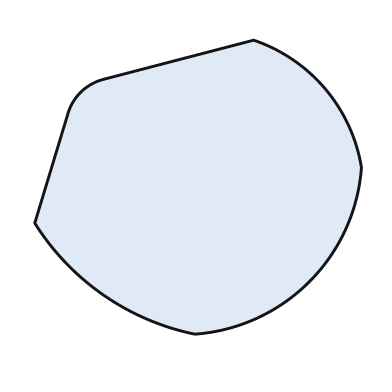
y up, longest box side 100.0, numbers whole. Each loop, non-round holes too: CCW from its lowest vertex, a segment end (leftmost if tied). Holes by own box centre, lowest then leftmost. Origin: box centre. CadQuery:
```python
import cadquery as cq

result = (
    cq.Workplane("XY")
    .moveTo(-1.0, -45.0)
    .threePointArc((34.0, -29.0), (50.0, 6.0))
    .threePointArc((39.0, 30.0), (17.0, 45.0))
    .lineTo(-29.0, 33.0)
    .threePointArc((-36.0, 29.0), (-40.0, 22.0))
    .lineTo(-50.0, -11.0)
    .threePointArc((-29.0, -33.0), (-1.0, -45.0))
    .close()
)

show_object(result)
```